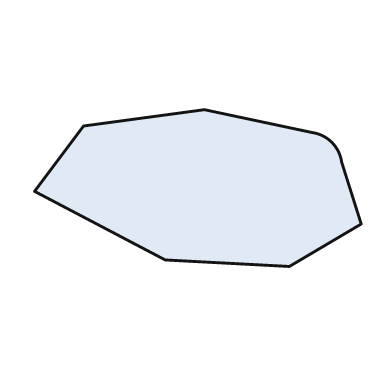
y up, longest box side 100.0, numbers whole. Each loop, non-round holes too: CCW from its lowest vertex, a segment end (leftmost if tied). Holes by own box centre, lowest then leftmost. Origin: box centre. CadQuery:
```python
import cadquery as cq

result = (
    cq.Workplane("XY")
    .moveTo(28.0, -24.0)
    .lineTo(50.0, -11.0)
    .lineTo(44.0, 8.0)
    .threePointArc((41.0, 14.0), (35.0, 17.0))
    .lineTo(2.0, 24.0)
    .lineTo(-35.0, 19.0)
    .lineTo(-50.0, -1.0)
    .lineTo(-10.0, -22.0)
    .close()
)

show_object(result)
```